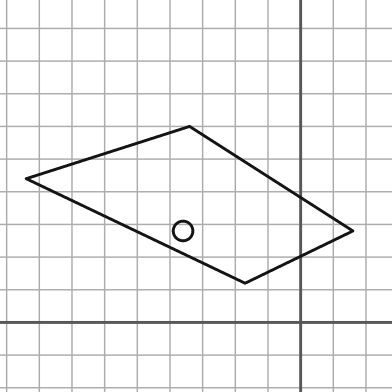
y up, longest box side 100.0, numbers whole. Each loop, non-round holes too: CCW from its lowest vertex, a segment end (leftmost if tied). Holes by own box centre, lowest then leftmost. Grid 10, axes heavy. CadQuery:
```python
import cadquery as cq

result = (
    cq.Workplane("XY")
    .moveTo(-17.0, 12.0)
    .lineTo(16.0, 28.0)
    .lineTo(-34.0, 60.0)
    .lineTo(-84.0, 44.0)
    .close()
    .moveTo(-36.0, 28.0)
    .circle(3.0)
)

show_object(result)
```